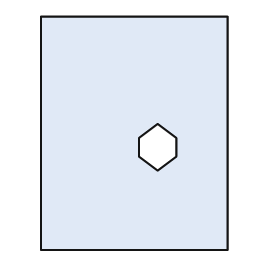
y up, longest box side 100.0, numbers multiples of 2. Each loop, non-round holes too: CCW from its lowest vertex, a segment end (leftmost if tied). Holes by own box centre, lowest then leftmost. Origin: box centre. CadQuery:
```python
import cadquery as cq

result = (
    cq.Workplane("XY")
    .moveTo(-40.0, -50.0)
    .lineTo(40.0, -50.0)
    .lineTo(40.0, 50.0)
    .lineTo(-40.0, 50.0)
    .close()
    .moveTo(10.0, -16.0)
    .lineTo(18.0, -10.0)
    .lineTo(18.0, -2.0)
    .lineTo(10.0, 4.0)
    .lineTo(2.0, -2.0)
    .lineTo(2.0, -10.0)
    .close()
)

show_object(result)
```